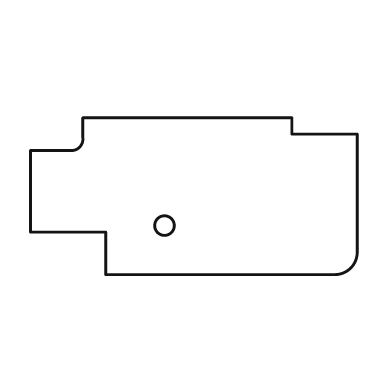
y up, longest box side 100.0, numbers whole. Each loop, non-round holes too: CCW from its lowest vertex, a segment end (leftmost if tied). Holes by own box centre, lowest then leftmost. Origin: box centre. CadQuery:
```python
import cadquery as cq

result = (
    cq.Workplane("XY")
    .moveTo(-27.0, -24.0)
    .lineTo(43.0, -24.0)
    .threePointArc((48.0, -22.0), (50.0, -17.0))
    .lineTo(50.0, 19.0)
    .lineTo(30.0, 19.0)
    .lineTo(30.0, 24.0)
    .lineTo(-34.0, 24.0)
    .lineTo(-34.0, 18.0)
    .threePointArc((-35.0, 15.0), (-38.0, 14.0))
    .lineTo(-50.0, 14.0)
    .lineTo(-50.0, -11.0)
    .lineTo(-27.0, -11.0)
    .close()
    .moveTo(-9.0, -9.0)
    .circle(3.0)
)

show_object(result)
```